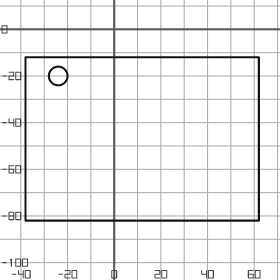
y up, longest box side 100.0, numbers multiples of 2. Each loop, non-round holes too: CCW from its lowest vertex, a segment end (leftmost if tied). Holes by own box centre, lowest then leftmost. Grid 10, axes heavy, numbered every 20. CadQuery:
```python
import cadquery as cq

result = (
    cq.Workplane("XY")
    .moveTo(-38.0, -82.0)
    .lineTo(62.0, -82.0)
    .lineTo(62.0, -12.0)
    .lineTo(-38.0, -12.0)
    .close()
    .moveTo(-24.0, -20.0)
    .circle(4.0)
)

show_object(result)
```